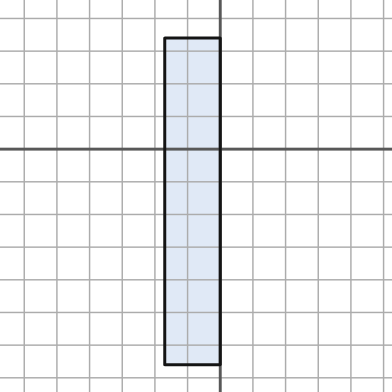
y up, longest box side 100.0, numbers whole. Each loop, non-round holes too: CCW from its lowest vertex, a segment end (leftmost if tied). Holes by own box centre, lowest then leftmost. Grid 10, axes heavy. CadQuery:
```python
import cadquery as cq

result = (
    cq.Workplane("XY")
    .moveTo(-17.0, -66.0)
    .lineTo(0.0, -66.0)
    .lineTo(0.0, 34.0)
    .lineTo(-17.0, 34.0)
    .close()
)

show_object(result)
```